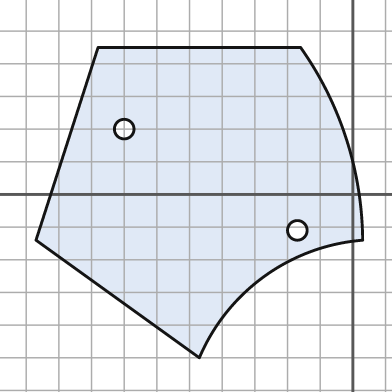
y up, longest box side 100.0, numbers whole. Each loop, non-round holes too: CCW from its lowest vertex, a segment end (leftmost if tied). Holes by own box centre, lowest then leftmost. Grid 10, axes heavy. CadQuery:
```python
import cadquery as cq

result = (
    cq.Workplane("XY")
    .moveTo(-47.0, -50.0)
    .threePointArc((-27.0, -25.0), (3.0, -14.0))
    .threePointArc((-2.0, 17.0), (-16.0, 45.0))
    .lineTo(-78.0, 45.0)
    .lineTo(-97.0, -14.0)
    .close()
    .moveTo(-17.0, -11.0)
    .circle(3.0)
    .moveTo(-70.0, 20.0)
    .circle(3.0)
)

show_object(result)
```